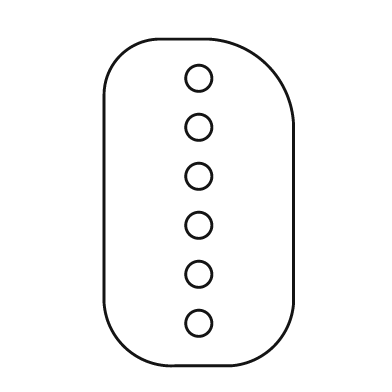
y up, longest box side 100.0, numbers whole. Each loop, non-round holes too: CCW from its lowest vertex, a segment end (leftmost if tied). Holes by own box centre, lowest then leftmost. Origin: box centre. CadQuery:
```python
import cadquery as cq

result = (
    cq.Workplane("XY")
    .moveTo(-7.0, -50.0)
    .lineTo(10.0, -50.0)
    .threePointArc((23.0, -44.0), (29.0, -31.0))
    .lineTo(29.0, 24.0)
    .threePointArc((21.0, 42.0), (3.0, 50.0))
    .lineTo(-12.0, 50.0)
    .threePointArc((-24.0, 45.0), (-29.0, 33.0))
    .lineTo(-29.0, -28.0)
    .threePointArc((-23.0, -44.0), (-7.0, -50.0))
    .close()
    .moveTo(0.0, -37.0)
    .circle(4.0)
    .moveTo(0.0, -22.0)
    .circle(4.0)
    .moveTo(0.0, -7.0)
    .circle(4.0)
    .moveTo(0.0, 8.0)
    .circle(4.0)
    .moveTo(0.0, 23.0)
    .circle(4.0)
    .moveTo(0.0, 38.0)
    .circle(4.0)
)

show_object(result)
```